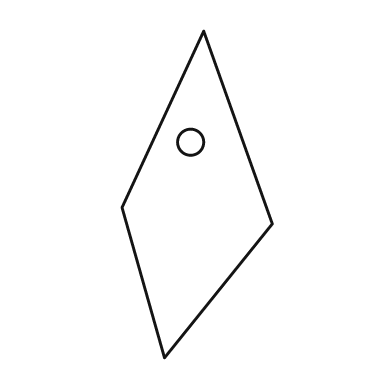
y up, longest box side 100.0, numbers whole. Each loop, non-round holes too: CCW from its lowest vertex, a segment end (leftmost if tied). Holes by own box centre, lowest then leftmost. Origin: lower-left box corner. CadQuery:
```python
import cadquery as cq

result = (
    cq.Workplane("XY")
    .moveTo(13.0, 0.0)
    .lineTo(46.0, 41.0)
    .lineTo(25.0, 100.0)
    .lineTo(0.0, 46.0)
    .close()
    .moveTo(21.0, 66.0)
    .circle(4.0)
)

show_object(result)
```